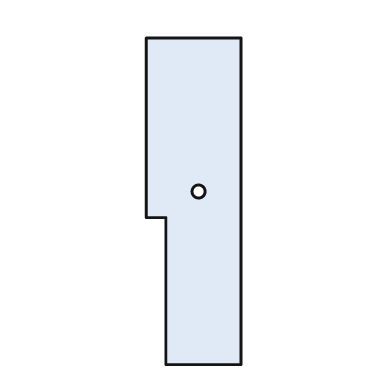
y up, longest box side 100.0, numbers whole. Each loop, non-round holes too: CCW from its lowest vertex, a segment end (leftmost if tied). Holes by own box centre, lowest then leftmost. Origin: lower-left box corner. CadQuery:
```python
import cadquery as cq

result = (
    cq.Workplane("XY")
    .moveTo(6.0, 0.0)
    .lineTo(29.0, 0.0)
    .lineTo(29.0, 100.0)
    .lineTo(0.0, 100.0)
    .lineTo(0.0, 45.0)
    .lineTo(6.0, 45.0)
    .close()
    .moveTo(16.0, 53.0)
    .circle(2.0)
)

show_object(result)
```